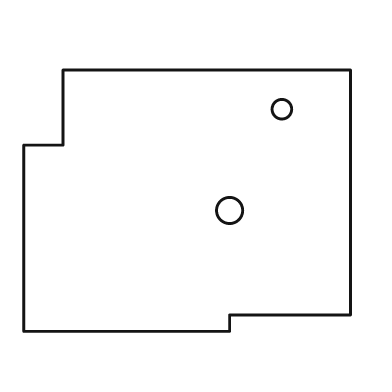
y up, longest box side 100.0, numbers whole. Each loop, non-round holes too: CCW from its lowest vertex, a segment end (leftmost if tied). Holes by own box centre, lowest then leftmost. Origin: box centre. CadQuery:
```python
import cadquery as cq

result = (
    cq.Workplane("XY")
    .moveTo(-50.0, -40.0)
    .lineTo(13.0, -40.0)
    .lineTo(13.0, -35.0)
    .lineTo(50.0, -35.0)
    .lineTo(50.0, 40.0)
    .lineTo(-38.0, 40.0)
    .lineTo(-38.0, 17.0)
    .lineTo(-50.0, 17.0)
    .close()
    .moveTo(13.0, -3.0)
    .circle(4.0)
    .moveTo(29.0, 28.0)
    .circle(3.0)
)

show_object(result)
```